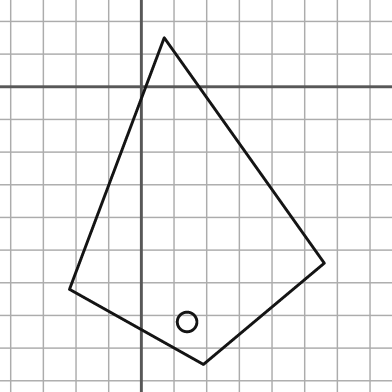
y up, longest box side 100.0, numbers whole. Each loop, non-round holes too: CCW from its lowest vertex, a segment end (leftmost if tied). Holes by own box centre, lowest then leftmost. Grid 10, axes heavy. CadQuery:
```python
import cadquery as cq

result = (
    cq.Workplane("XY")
    .moveTo(19.0, -85.0)
    .lineTo(56.0, -54.0)
    .lineTo(7.0, 15.0)
    .lineTo(-22.0, -62.0)
    .close()
    .moveTo(14.0, -72.0)
    .circle(3.0)
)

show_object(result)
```